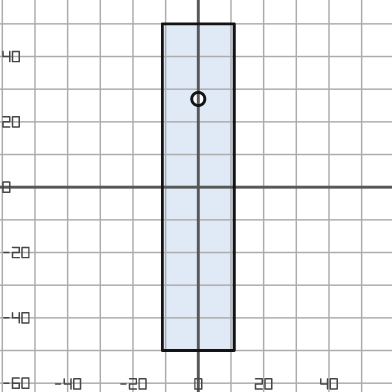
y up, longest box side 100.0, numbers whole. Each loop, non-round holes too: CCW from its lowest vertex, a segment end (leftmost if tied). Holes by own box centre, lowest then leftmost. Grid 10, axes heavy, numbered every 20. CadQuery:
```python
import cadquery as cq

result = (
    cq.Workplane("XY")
    .moveTo(-11.0, -50.0)
    .lineTo(11.0, -50.0)
    .lineTo(11.0, 50.0)
    .lineTo(-11.0, 50.0)
    .close()
    .moveTo(0.0, 27.0)
    .circle(2.0)
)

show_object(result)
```